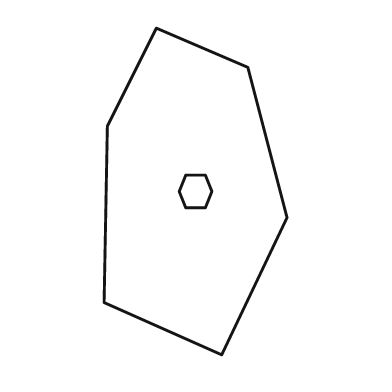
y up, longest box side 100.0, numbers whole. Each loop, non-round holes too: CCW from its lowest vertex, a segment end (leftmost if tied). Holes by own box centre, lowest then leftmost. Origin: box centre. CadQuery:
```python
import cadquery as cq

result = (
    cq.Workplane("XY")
    .moveTo(8.0, -50.0)
    .lineTo(28.0, -8.0)
    .lineTo(16.0, 38.0)
    .lineTo(-12.0, 50.0)
    .lineTo(-27.0, 20.0)
    .lineTo(-28.0, -34.0)
    .close()
    .moveTo(-3.0, -5.0)
    .lineTo(3.0, -5.0)
    .lineTo(5.0, 0.0)
    .lineTo(3.0, 5.0)
    .lineTo(-3.0, 5.0)
    .lineTo(-5.0, 0.0)
    .close()
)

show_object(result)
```